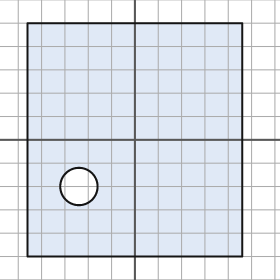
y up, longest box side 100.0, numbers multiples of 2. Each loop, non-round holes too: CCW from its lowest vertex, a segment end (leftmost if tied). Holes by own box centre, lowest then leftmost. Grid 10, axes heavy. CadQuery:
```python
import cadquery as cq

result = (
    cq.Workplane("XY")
    .moveTo(-46.0, -50.0)
    .lineTo(46.0, -50.0)
    .lineTo(46.0, 50.0)
    .lineTo(-46.0, 50.0)
    .close()
    .moveTo(-24.0, -20.0)
    .circle(8.0)
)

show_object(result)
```